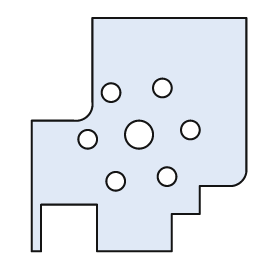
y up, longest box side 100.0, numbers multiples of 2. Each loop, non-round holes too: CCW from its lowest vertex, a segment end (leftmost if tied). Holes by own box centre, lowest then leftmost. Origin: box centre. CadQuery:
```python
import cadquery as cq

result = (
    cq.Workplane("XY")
    .moveTo(-46.0, -50.0)
    .lineTo(-42.0, -50.0)
    .lineTo(-42.0, -30.0)
    .lineTo(-18.0, -30.0)
    .lineTo(-18.0, -50.0)
    .lineTo(14.0, -50.0)
    .lineTo(14.0, -34.0)
    .lineTo(26.0, -34.0)
    .lineTo(26.0, -22.0)
    .lineTo(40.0, -22.0)
    .threePointArc((44.0, -20.0), (46.0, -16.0))
    .lineTo(46.0, 50.0)
    .lineTo(-20.0, 50.0)
    .lineTo(-20.0, 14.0)
    .threePointArc((-22.0, 8.0), (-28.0, 6.0))
    .lineTo(-46.0, 6.0)
    .close()
    .moveTo(-10.0, -20.0)
    .circle(4.0)
    .moveTo(12.0, -18.0)
    .circle(4.0)
    .moveTo(-22.0, -2.0)
    .circle(4.0)
    .moveTo(0.0, 0.0)
    .circle(6.0)
    .moveTo(22.0, 2.0)
    .circle(4.0)
    .moveTo(-12.0, 18.0)
    .circle(4.0)
    .moveTo(10.0, 20.0)
    .circle(4.0)
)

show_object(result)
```